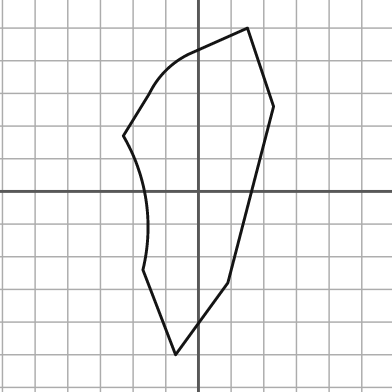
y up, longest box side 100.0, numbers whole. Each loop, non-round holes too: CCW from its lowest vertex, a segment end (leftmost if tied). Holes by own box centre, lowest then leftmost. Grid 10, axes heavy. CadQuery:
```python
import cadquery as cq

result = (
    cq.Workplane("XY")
    .moveTo(-7.0, -50.0)
    .lineTo(9.0, -28.0)
    .lineTo(23.0, 26.0)
    .lineTo(15.0, 50.0)
    .lineTo(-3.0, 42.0)
    .threePointArc((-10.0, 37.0), (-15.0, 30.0))
    .lineTo(-23.0, 17.0)
    .threePointArc((-16.0, -3.0), (-17.0, -24.0))
    .close()
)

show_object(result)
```